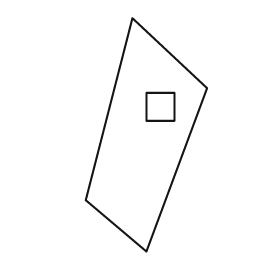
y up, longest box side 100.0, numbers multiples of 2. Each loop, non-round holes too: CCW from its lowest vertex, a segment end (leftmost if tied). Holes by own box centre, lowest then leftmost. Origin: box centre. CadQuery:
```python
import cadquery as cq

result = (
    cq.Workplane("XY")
    .moveTo(0.0, -50.0)
    .lineTo(26.0, 20.0)
    .lineTo(-6.0, 50.0)
    .lineTo(-26.0, -28.0)
    .close()
    .moveTo(0.0, 6.0)
    .lineTo(12.0, 6.0)
    .lineTo(12.0, 18.0)
    .lineTo(0.0, 18.0)
    .close()
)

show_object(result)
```